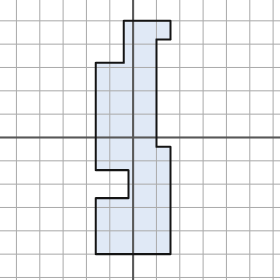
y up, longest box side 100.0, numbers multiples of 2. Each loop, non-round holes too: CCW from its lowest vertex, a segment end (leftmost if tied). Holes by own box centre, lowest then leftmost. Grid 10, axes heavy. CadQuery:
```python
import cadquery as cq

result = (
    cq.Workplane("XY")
    .moveTo(-16.0, -50.0)
    .lineTo(16.0, -50.0)
    .lineTo(16.0, -4.0)
    .lineTo(10.0, -4.0)
    .lineTo(10.0, 42.0)
    .lineTo(16.0, 42.0)
    .lineTo(16.0, 50.0)
    .lineTo(-4.0, 50.0)
    .lineTo(-4.0, 32.0)
    .lineTo(-16.0, 32.0)
    .lineTo(-16.0, -14.0)
    .lineTo(-2.0, -14.0)
    .lineTo(-2.0, -26.0)
    .lineTo(-16.0, -26.0)
    .close()
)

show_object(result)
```